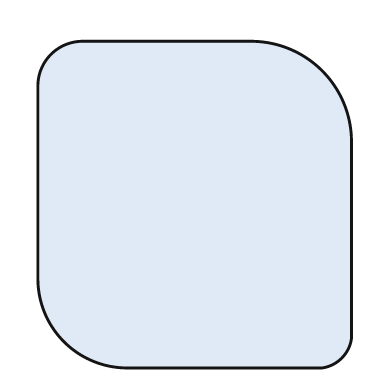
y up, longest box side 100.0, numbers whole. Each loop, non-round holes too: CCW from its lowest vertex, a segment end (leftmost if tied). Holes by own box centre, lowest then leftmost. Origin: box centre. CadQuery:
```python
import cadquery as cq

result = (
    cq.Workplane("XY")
    .moveTo(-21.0, -50.0)
    .lineTo(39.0, -50.0)
    .threePointArc((45.0, -47.0), (48.0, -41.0))
    .lineTo(48.0, 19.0)
    .threePointArc((39.0, 41.0), (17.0, 50.0))
    .lineTo(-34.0, 50.0)
    .threePointArc((-44.0, 46.0), (-48.0, 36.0))
    .lineTo(-48.0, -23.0)
    .threePointArc((-40.0, -42.0), (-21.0, -50.0))
    .close()
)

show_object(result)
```